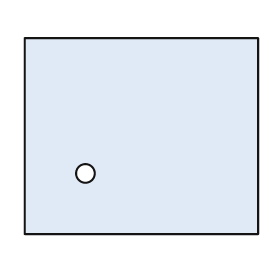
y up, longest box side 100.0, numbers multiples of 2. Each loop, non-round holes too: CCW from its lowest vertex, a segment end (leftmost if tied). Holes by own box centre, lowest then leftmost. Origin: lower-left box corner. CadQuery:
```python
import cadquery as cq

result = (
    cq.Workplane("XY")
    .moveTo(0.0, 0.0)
    .lineTo(100.0, 0.0)
    .lineTo(100.0, 84.0)
    .lineTo(0.0, 84.0)
    .close()
    .moveTo(26.0, 26.0)
    .circle(4.0)
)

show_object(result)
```